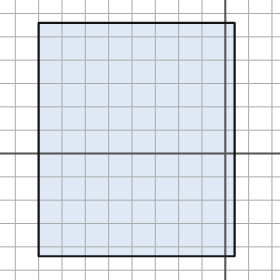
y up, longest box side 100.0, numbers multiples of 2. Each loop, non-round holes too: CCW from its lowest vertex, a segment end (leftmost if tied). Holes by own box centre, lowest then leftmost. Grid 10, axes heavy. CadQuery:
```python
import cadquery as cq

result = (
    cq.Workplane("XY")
    .moveTo(-80.0, -44.0)
    .lineTo(4.0, -44.0)
    .lineTo(4.0, 56.0)
    .lineTo(-80.0, 56.0)
    .close()
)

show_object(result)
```